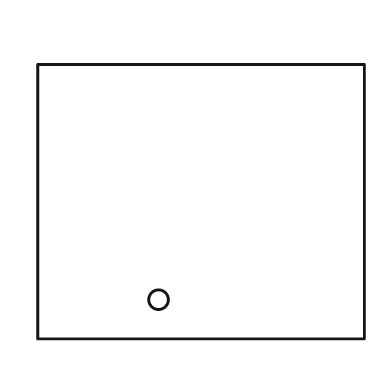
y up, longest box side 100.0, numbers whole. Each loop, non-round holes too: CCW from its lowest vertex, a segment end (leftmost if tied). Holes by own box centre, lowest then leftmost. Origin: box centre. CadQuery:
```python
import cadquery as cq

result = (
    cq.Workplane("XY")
    .moveTo(-50.0, -42.0)
    .lineTo(50.0, -42.0)
    .lineTo(50.0, 42.0)
    .lineTo(-50.0, 42.0)
    .close()
    .moveTo(-13.0, -30.0)
    .circle(3.0)
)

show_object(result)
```